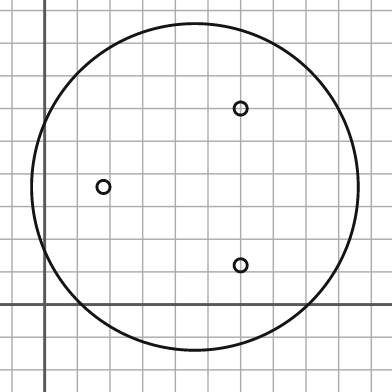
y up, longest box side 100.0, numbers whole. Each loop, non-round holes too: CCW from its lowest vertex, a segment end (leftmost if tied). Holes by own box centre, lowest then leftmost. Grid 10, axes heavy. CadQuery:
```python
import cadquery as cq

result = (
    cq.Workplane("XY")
    .moveTo(46.0, 36.0)
    .circle(50.0)
    .moveTo(60.0, 12.0)
    .circle(2.0)
    .moveTo(18.0, 36.0)
    .circle(2.0)
    .moveTo(60.0, 60.0)
    .circle(2.0)
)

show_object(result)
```